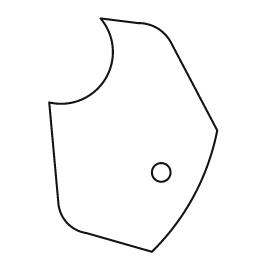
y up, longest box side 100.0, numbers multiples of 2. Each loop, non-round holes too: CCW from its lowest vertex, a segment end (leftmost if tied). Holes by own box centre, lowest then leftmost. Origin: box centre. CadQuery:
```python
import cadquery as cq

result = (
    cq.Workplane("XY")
    .moveTo(8.0, -50.0)
    .threePointArc((26.0, -26.0), (36.0, 2.0))
    .lineTo(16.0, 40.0)
    .threePointArc((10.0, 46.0), (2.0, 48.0))
    .lineTo(-14.0, 50.0)
    .threePointArc((-12.0, 24.0), (-36.0, 14.0))
    .lineTo(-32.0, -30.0)
    .threePointArc((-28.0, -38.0), (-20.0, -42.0))
    .close()
    .moveTo(12.0, -16.0)
    .circle(4.0)
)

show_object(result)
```